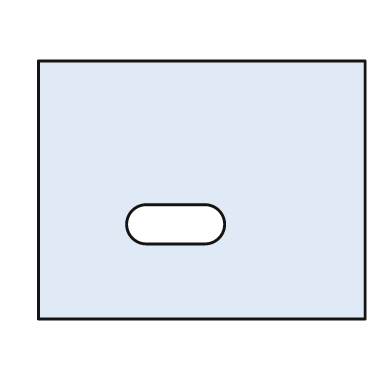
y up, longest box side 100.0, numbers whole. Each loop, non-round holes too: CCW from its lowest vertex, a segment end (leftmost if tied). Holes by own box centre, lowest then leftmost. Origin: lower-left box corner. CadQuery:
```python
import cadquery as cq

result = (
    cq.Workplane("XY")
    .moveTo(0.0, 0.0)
    .lineTo(100.0, 0.0)
    .lineTo(100.0, 79.0)
    .lineTo(0.0, 79.0)
    .close()
    .moveTo(33.0, 23.0)
    .lineTo(51.0, 23.0)
    .threePointArc((57.0, 29.0), (51.0, 35.0))
    .lineTo(33.0, 35.0)
    .threePointArc((27.0, 29.0), (33.0, 23.0))
    .close()
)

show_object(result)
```